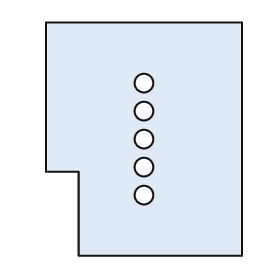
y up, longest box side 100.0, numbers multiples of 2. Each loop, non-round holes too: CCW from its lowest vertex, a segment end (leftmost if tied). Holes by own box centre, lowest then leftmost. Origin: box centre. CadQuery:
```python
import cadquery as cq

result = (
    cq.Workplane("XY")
    .moveTo(-28.0, -50.0)
    .lineTo(42.0, -50.0)
    .lineTo(42.0, 50.0)
    .lineTo(-42.0, 50.0)
    .lineTo(-42.0, -14.0)
    .lineTo(-28.0, -14.0)
    .close()
    .moveTo(0.0, -24.0)
    .circle(4.0)
    .moveTo(0.0, -12.0)
    .circle(4.0)
    .moveTo(0.0, 0.0)
    .circle(4.0)
    .moveTo(0.0, 12.0)
    .circle(4.0)
    .moveTo(0.0, 24.0)
    .circle(4.0)
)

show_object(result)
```